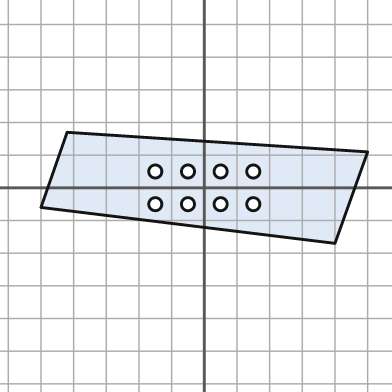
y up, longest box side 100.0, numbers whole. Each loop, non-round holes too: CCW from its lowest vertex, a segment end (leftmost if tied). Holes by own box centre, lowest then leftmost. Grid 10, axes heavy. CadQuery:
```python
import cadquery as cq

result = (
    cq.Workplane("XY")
    .moveTo(40.0, -17.0)
    .lineTo(50.0, 11.0)
    .lineTo(-42.0, 17.0)
    .lineTo(-50.0, -6.0)
    .close()
    .moveTo(-15.0, -5.0)
    .circle(2.0)
    .moveTo(-5.0, -5.0)
    .circle(2.0)
    .moveTo(5.0, -5.0)
    .circle(2.0)
    .moveTo(15.0, -5.0)
    .circle(2.0)
    .moveTo(-15.0, 5.0)
    .circle(2.0)
    .moveTo(-5.0, 5.0)
    .circle(2.0)
    .moveTo(5.0, 5.0)
    .circle(2.0)
    .moveTo(15.0, 5.0)
    .circle(2.0)
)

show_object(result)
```